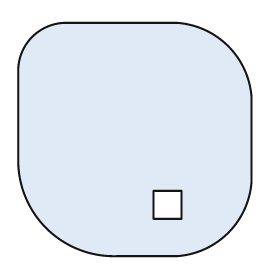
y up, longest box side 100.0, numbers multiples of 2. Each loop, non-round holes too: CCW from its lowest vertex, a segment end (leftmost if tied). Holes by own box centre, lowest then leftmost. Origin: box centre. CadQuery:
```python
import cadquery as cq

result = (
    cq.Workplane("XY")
    .moveTo(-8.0, -50.0)
    .lineTo(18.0, -50.0)
    .threePointArc((40.0, -40.0), (50.0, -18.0))
    .lineTo(50.0, 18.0)
    .threePointArc((40.0, 40.0), (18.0, 50.0))
    .lineTo(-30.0, 50.0)
    .threePointArc((-44.0, 44.0), (-50.0, 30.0))
    .lineTo(-50.0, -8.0)
    .threePointArc((-38.0, -38.0), (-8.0, -50.0))
    .close()
    .moveTo(8.0, -34.0)
    .lineTo(20.0, -34.0)
    .lineTo(20.0, -22.0)
    .lineTo(8.0, -22.0)
    .close()
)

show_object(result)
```